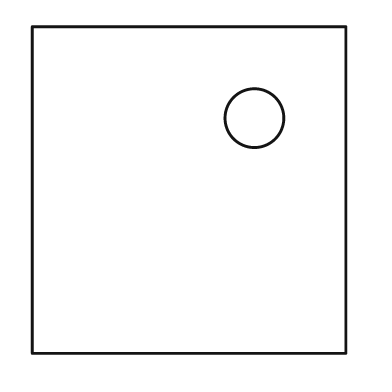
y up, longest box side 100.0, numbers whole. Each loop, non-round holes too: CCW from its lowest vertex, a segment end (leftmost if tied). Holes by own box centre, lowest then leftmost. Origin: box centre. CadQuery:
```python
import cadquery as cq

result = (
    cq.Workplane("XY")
    .moveTo(-48.0, -50.0)
    .lineTo(48.0, -50.0)
    .lineTo(48.0, 50.0)
    .lineTo(-48.0, 50.0)
    .close()
    .moveTo(20.0, 22.0)
    .circle(9.0)
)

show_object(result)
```